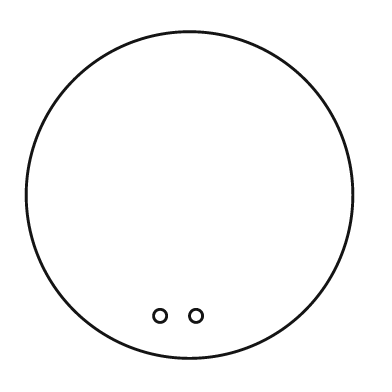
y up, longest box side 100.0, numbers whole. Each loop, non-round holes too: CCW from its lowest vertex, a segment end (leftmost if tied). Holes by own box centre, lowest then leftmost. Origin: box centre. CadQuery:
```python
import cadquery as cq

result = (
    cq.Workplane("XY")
    .moveTo(0.0, 0.0)
    .circle(50.0)
    .moveTo(-9.0, -37.0)
    .circle(2.0)
    .moveTo(2.0, -37.0)
    .circle(2.0)
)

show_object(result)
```